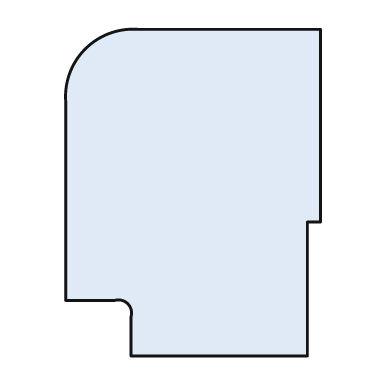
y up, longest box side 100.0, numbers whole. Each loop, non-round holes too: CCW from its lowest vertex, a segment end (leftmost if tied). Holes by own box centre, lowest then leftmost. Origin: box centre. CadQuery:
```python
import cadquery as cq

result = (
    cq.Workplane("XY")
    .moveTo(-19.0, -50.0)
    .lineTo(35.0, -50.0)
    .lineTo(35.0, -9.0)
    .lineTo(39.0, -9.0)
    .lineTo(39.0, 50.0)
    .lineTo(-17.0, 50.0)
    .threePointArc((-33.0, 44.0), (-39.0, 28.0))
    .lineTo(-39.0, -33.0)
    .lineTo(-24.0, -33.0)
    .threePointArc((-20.0, -34.0), (-19.0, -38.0))
    .close()
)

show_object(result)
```